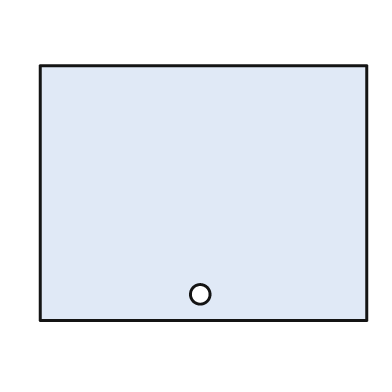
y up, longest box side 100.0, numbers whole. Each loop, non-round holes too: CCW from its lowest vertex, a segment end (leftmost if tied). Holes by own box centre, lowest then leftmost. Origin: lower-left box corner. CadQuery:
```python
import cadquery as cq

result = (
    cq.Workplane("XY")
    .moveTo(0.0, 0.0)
    .lineTo(100.0, 0.0)
    .lineTo(100.0, 78.0)
    .lineTo(0.0, 78.0)
    .close()
    .moveTo(49.0, 8.0)
    .circle(3.0)
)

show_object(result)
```